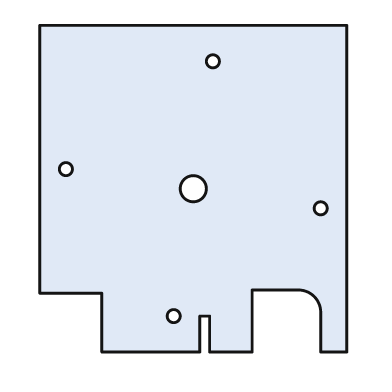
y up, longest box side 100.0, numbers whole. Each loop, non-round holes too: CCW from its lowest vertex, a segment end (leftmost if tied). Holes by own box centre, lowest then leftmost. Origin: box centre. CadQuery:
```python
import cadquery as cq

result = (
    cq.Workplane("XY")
    .moveTo(-28.0, -50.0)
    .lineTo(2.0, -50.0)
    .lineTo(2.0, -39.0)
    .lineTo(5.0, -39.0)
    .lineTo(5.0, -50.0)
    .lineTo(18.0, -50.0)
    .lineTo(18.0, -31.0)
    .lineTo(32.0, -31.0)
    .threePointArc((37.0, -33.0), (39.0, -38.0))
    .lineTo(39.0, -50.0)
    .lineTo(47.0, -50.0)
    .lineTo(47.0, 50.0)
    .lineTo(-47.0, 50.0)
    .lineTo(-47.0, -32.0)
    .lineTo(-28.0, -32.0)
    .close()
    .moveTo(-6.0, -39.0)
    .circle(2.0)
    .moveTo(39.0, -6.0)
    .circle(2.0)
    .moveTo(0.0, 0.0)
    .circle(4.0)
    .moveTo(-39.0, 6.0)
    .circle(2.0)
    .moveTo(6.0, 39.0)
    .circle(2.0)
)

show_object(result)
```